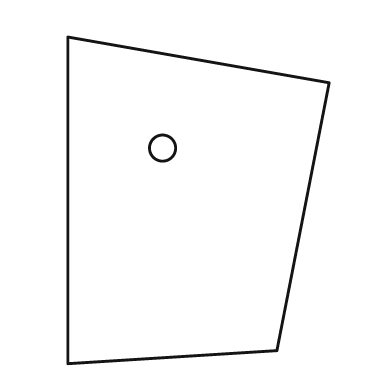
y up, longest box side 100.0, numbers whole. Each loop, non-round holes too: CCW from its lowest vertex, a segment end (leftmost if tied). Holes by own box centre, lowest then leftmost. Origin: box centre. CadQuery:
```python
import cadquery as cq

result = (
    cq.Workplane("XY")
    .moveTo(-40.0, -50.0)
    .lineTo(24.0, -46.0)
    .lineTo(40.0, 36.0)
    .lineTo(-40.0, 50.0)
    .close()
    .moveTo(-11.0, 16.0)
    .circle(4.0)
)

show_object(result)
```